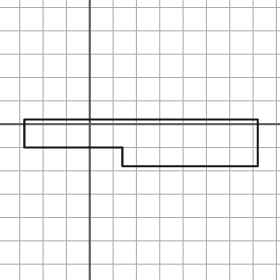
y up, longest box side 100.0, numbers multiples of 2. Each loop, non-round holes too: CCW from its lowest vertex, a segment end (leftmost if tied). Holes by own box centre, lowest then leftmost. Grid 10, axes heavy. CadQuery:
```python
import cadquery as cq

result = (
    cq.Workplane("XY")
    .moveTo(14.0, -18.0)
    .lineTo(72.0, -18.0)
    .lineTo(72.0, 2.0)
    .lineTo(-28.0, 2.0)
    .lineTo(-28.0, -10.0)
    .lineTo(14.0, -10.0)
    .close()
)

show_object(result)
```